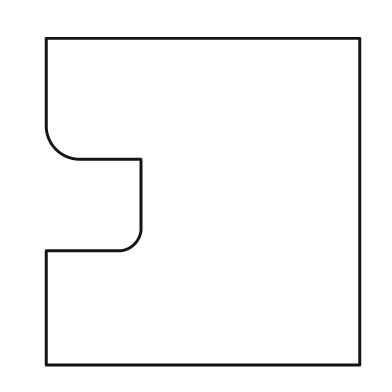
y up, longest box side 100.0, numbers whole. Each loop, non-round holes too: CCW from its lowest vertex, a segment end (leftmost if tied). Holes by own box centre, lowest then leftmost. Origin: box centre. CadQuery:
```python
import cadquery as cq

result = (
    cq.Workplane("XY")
    .moveTo(-48.0, -50.0)
    .lineTo(48.0, -50.0)
    .lineTo(48.0, 50.0)
    .lineTo(-48.0, 50.0)
    .lineTo(-48.0, 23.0)
    .threePointArc((-45.0, 16.0), (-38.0, 13.0))
    .lineTo(-19.0, 13.0)
    .lineTo(-19.0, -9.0)
    .threePointArc((-21.0, -13.0), (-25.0, -15.0))
    .lineTo(-48.0, -15.0)
    .close()
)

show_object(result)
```